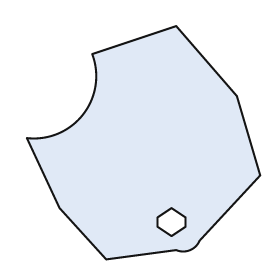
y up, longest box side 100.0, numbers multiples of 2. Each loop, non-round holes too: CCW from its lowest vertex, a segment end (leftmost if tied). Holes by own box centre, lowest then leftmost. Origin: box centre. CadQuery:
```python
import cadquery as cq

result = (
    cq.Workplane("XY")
    .moveTo(-16.0, -50.0)
    .lineTo(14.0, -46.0)
    .threePointArc((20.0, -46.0), (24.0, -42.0))
    .lineTo(50.0, -14.0)
    .lineTo(40.0, 20.0)
    .lineTo(14.0, 50.0)
    .lineTo(-22.0, 38.0)
    .threePointArc((-26.0, 12.0), (-50.0, 2.0))
    .lineTo(-36.0, -28.0)
    .close()
    .moveTo(12.0, -40.0)
    .lineTo(18.0, -36.0)
    .lineTo(18.0, -32.0)
    .lineTo(12.0, -28.0)
    .lineTo(6.0, -32.0)
    .lineTo(6.0, -36.0)
    .close()
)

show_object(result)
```